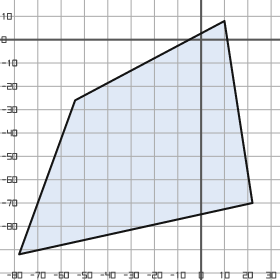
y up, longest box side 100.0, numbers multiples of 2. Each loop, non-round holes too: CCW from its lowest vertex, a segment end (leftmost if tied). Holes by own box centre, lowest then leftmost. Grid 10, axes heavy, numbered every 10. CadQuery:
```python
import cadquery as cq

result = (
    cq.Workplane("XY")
    .moveTo(-78.0, -92.0)
    .lineTo(22.0, -70.0)
    .lineTo(10.0, 8.0)
    .lineTo(-54.0, -26.0)
    .close()
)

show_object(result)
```